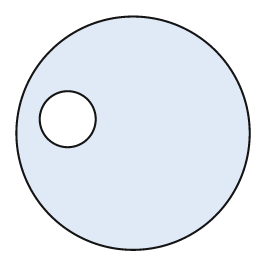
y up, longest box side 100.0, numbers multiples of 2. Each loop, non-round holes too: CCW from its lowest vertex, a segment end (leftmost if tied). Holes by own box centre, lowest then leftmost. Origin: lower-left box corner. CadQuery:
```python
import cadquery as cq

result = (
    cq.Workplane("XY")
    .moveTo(50.0, 50.0)
    .circle(50.0)
    .moveTo(22.0, 56.0)
    .circle(12.0)
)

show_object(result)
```